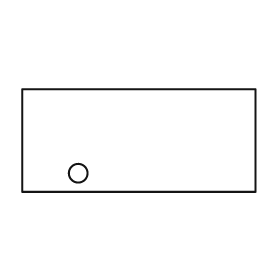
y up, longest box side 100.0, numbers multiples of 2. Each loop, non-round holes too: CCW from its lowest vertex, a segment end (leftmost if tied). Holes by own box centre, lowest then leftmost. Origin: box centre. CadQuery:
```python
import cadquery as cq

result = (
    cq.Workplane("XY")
    .moveTo(-50.0, -22.0)
    .lineTo(50.0, -22.0)
    .lineTo(50.0, 22.0)
    .lineTo(-50.0, 22.0)
    .close()
    .moveTo(-26.0, -14.0)
    .circle(4.0)
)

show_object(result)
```